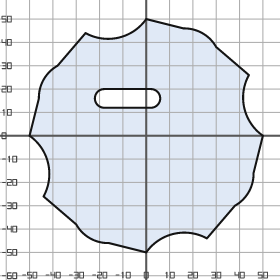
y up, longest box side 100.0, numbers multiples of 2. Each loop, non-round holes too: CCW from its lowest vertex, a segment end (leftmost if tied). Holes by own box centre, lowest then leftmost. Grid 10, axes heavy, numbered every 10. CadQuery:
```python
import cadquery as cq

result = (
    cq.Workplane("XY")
    .moveTo(0.0, -50.0)
    .threePointArc((12.0, -42.0), (26.0, -44.0))
    .lineTo(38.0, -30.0)
    .threePointArc((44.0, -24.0), (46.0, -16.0))
    .lineTo(50.0, 0.0)
    .threePointArc((42.0, 12.0), (44.0, 26.0))
    .lineTo(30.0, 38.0)
    .threePointArc((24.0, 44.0), (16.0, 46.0))
    .lineTo(0.0, 50.0)
    .threePointArc((-12.0, 42.0), (-26.0, 44.0))
    .lineTo(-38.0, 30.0)
    .threePointArc((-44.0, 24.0), (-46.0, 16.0))
    .lineTo(-50.0, 0.0)
    .threePointArc((-42.0, -12.0), (-44.0, -26.0))
    .lineTo(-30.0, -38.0)
    .threePointArc((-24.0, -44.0), (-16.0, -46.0))
    .close()
    .moveTo(-18.0, 12.0)
    .lineTo(2.0, 12.0)
    .threePointArc((6.0, 16.0), (2.0, 20.0))
    .lineTo(-18.0, 20.0)
    .threePointArc((-22.0, 16.0), (-18.0, 12.0))
    .close()
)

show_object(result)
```